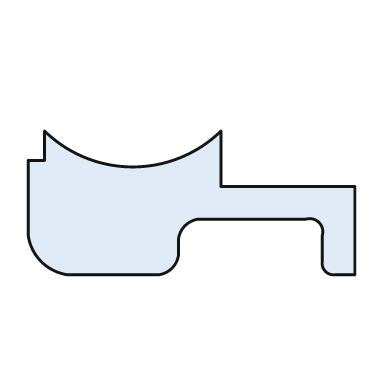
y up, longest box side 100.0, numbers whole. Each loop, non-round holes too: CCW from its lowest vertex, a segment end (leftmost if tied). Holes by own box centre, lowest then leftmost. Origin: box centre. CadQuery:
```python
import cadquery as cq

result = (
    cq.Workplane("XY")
    .moveTo(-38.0, -22.0)
    .lineTo(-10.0, -22.0)
    .threePointArc((-6.0, -20.0), (-4.0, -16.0))
    .lineTo(-4.0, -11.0)
    .threePointArc((-2.0, -7.0), (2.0, -5.0))
    .lineTo(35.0, -5.0)
    .threePointArc((39.0, -6.0), (40.0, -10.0))
    .lineTo(40.0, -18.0)
    .threePointArc((41.0, -21.0), (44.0, -22.0))
    .lineTo(50.0, -22.0)
    .lineTo(50.0, 5.0)
    .lineTo(9.0, 5.0)
    .lineTo(9.0, 22.0)
    .threePointArc((-18.0, 11.0), (-45.0, 22.0))
    .lineTo(-45.0, 13.0)
    .lineTo(-50.0, 13.0)
    .lineTo(-50.0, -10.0)
    .threePointArc((-46.0, -18.0), (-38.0, -22.0))
    .close()
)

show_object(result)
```